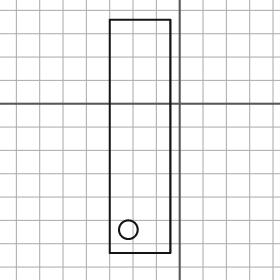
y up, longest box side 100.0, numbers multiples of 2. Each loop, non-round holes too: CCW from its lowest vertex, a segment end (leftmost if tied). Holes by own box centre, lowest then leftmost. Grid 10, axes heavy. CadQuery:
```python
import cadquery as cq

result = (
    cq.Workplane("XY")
    .moveTo(-30.0, -64.0)
    .lineTo(-4.0, -64.0)
    .lineTo(-4.0, 36.0)
    .lineTo(-30.0, 36.0)
    .close()
    .moveTo(-22.0, -54.0)
    .circle(4.0)
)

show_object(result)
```